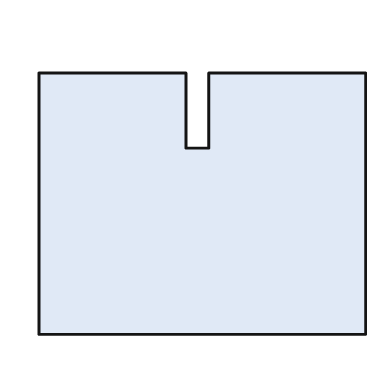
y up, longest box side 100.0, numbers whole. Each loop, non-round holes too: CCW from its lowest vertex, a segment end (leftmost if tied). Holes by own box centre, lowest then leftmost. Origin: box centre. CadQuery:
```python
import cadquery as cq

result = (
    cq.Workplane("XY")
    .moveTo(-50.0, -40.0)
    .lineTo(50.0, -40.0)
    .lineTo(50.0, 40.0)
    .lineTo(2.0, 40.0)
    .lineTo(2.0, 17.0)
    .lineTo(-5.0, 17.0)
    .lineTo(-5.0, 40.0)
    .lineTo(-50.0, 40.0)
    .close()
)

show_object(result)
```